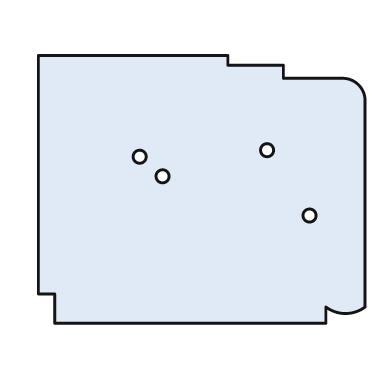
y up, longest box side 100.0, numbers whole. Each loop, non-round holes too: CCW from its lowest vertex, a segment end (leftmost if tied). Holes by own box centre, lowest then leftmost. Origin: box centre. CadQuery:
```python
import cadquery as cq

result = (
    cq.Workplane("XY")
    .moveTo(-45.0, -41.0)
    .lineTo(38.0, -41.0)
    .lineTo(38.0, -36.0)
    .threePointArc((44.0, -38.0), (50.0, -36.0))
    .lineTo(50.0, 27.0)
    .threePointArc((48.0, 32.0), (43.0, 34.0))
    .lineTo(25.0, 34.0)
    .lineTo(25.0, 38.0)
    .lineTo(8.0, 38.0)
    .lineTo(8.0, 41.0)
    .lineTo(-50.0, 41.0)
    .lineTo(-50.0, -32.0)
    .lineTo(-45.0, -32.0)
    .close()
    .moveTo(33.0, -8.0)
    .circle(2.0)
    .moveTo(-12.0, 4.0)
    .circle(2.0)
    .moveTo(-19.0, 10.0)
    .circle(2.0)
    .moveTo(20.0, 12.0)
    .circle(2.0)
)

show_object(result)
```